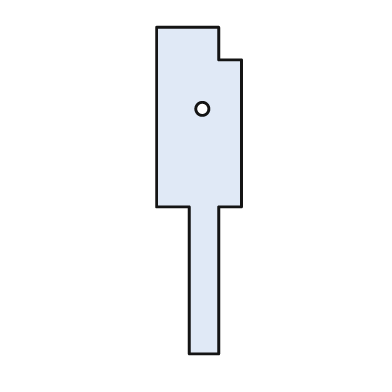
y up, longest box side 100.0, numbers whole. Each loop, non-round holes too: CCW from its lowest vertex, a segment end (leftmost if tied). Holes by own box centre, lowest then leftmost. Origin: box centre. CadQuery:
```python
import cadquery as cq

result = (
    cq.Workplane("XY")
    .moveTo(-3.0, -50.0)
    .lineTo(6.0, -50.0)
    .lineTo(6.0, -5.0)
    .lineTo(13.0, -5.0)
    .lineTo(13.0, 40.0)
    .lineTo(6.0, 40.0)
    .lineTo(6.0, 50.0)
    .lineTo(-13.0, 50.0)
    .lineTo(-13.0, -5.0)
    .lineTo(-3.0, -5.0)
    .close()
    .moveTo(1.0, 25.0)
    .circle(2.0)
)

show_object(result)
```